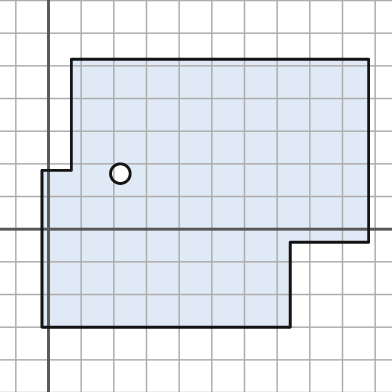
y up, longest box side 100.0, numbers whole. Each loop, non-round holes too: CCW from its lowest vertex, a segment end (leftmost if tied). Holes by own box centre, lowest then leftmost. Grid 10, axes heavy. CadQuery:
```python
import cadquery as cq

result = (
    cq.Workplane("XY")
    .moveTo(-2.0, -30.0)
    .lineTo(74.0, -30.0)
    .lineTo(74.0, -4.0)
    .lineTo(98.0, -4.0)
    .lineTo(98.0, 52.0)
    .lineTo(7.0, 52.0)
    .lineTo(7.0, 18.0)
    .lineTo(-2.0, 18.0)
    .close()
    .moveTo(22.0, 17.0)
    .circle(3.0)
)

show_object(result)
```